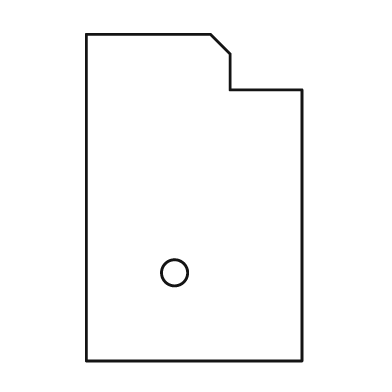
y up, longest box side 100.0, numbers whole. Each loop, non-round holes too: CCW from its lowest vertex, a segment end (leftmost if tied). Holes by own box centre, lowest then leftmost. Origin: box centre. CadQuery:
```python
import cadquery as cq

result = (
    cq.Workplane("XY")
    .moveTo(-33.0, -50.0)
    .lineTo(33.0, -50.0)
    .lineTo(33.0, 33.0)
    .lineTo(11.0, 33.0)
    .lineTo(11.0, 44.0)
    .lineTo(5.0, 50.0)
    .lineTo(-33.0, 50.0)
    .close()
    .moveTo(-6.0, -23.0)
    .circle(4.0)
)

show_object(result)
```